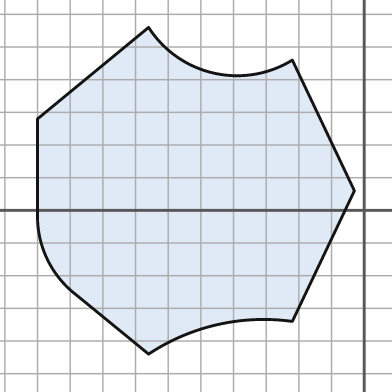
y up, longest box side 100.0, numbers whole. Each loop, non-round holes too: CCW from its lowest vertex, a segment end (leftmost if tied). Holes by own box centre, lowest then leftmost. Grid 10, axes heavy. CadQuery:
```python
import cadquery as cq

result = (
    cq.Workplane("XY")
    .moveTo(-66.0, -44.0)
    .threePointArc((-45.0, -35.0), (-22.0, -34.0))
    .lineTo(-3.0, 6.0)
    .lineTo(-22.0, 46.0)
    .threePointArc((-46.0, 42.0), (-66.0, 56.0))
    .lineTo(-100.0, 28.0)
    .lineTo(-100.0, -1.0)
    .threePointArc((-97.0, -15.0), (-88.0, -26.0))
    .close()
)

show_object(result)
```